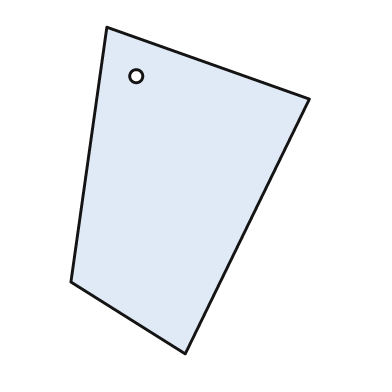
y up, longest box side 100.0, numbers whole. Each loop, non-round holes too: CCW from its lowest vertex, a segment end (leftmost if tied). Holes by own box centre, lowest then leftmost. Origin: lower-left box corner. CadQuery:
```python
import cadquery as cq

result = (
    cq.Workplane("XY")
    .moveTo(35.0, 0.0)
    .lineTo(73.0, 78.0)
    .lineTo(11.0, 100.0)
    .lineTo(0.0, 22.0)
    .close()
    .moveTo(20.0, 85.0)
    .circle(2.0)
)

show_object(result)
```